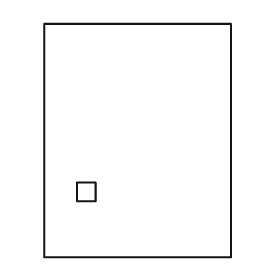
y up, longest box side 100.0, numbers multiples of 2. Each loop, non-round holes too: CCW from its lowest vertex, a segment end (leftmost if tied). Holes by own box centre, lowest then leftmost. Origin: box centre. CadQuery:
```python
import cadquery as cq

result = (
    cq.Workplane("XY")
    .moveTo(-40.0, -50.0)
    .lineTo(40.0, -50.0)
    .lineTo(40.0, 50.0)
    .lineTo(-40.0, 50.0)
    .close()
    .moveTo(-26.0, -26.0)
    .lineTo(-18.0, -26.0)
    .lineTo(-18.0, -18.0)
    .lineTo(-26.0, -18.0)
    .close()
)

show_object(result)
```